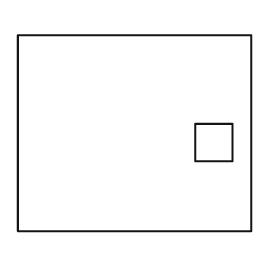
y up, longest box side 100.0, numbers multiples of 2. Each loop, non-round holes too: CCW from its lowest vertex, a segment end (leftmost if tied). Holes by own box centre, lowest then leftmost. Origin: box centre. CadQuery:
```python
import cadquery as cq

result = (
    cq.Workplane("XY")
    .moveTo(-50.0, -42.0)
    .lineTo(50.0, -42.0)
    .lineTo(50.0, 42.0)
    .lineTo(-50.0, 42.0)
    .close()
    .moveTo(26.0, -12.0)
    .lineTo(42.0, -12.0)
    .lineTo(42.0, 4.0)
    .lineTo(26.0, 4.0)
    .close()
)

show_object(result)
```